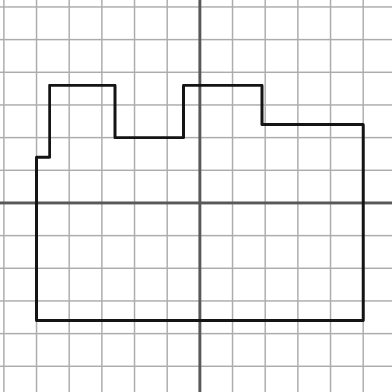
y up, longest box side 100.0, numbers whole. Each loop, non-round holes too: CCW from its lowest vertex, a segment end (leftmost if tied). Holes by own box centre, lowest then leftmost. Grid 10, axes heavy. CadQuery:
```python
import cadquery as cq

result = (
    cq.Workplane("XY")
    .moveTo(-50.0, -36.0)
    .lineTo(50.0, -36.0)
    .lineTo(50.0, 24.0)
    .lineTo(19.0, 24.0)
    .lineTo(19.0, 36.0)
    .lineTo(-5.0, 36.0)
    .lineTo(-5.0, 20.0)
    .lineTo(-26.0, 20.0)
    .lineTo(-26.0, 36.0)
    .lineTo(-46.0, 36.0)
    .lineTo(-46.0, 14.0)
    .lineTo(-50.0, 14.0)
    .close()
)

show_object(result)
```